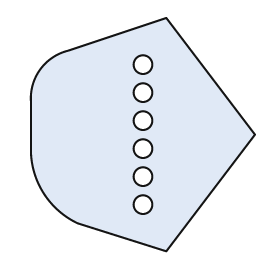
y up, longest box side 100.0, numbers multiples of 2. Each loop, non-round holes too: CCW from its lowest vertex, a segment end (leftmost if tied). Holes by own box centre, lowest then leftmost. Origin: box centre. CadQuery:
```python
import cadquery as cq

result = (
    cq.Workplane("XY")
    .moveTo(10.0, -50.0)
    .lineTo(48.0, 0.0)
    .lineTo(10.0, 50.0)
    .lineTo(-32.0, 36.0)
    .threePointArc((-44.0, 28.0), (-48.0, 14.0))
    .lineTo(-48.0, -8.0)
    .threePointArc((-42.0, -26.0), (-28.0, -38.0))
    .close()
    .moveTo(0.0, -30.0)
    .circle(4.0)
    .moveTo(0.0, -18.0)
    .circle(4.0)
    .moveTo(0.0, -6.0)
    .circle(4.0)
    .moveTo(0.0, 6.0)
    .circle(4.0)
    .moveTo(0.0, 18.0)
    .circle(4.0)
    .moveTo(0.0, 30.0)
    .circle(4.0)
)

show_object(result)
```